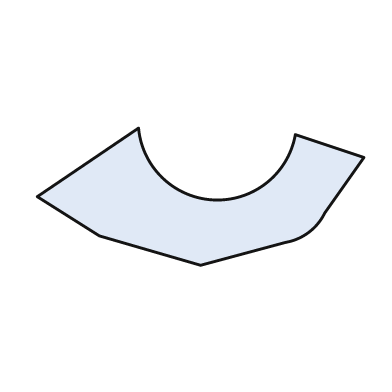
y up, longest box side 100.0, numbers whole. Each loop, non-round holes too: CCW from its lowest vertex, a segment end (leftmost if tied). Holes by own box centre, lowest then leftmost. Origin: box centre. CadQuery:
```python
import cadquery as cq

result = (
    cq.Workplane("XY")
    .moveTo(0.0, -21.0)
    .lineTo(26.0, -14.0)
    .threePointArc((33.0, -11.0), (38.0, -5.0))
    .lineTo(50.0, 12.0)
    .lineTo(29.0, 19.0)
    .threePointArc((4.0, -1.0), (-19.0, 21.0))
    .lineTo(-50.0, 0.0)
    .lineTo(-31.0, -12.0)
    .close()
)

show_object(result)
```